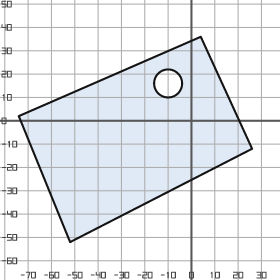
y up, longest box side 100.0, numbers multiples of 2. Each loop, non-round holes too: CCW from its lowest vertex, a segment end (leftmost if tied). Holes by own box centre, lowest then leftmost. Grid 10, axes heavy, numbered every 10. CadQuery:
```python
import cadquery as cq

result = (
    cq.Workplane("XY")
    .moveTo(-52.0, -52.0)
    .lineTo(26.0, -12.0)
    .lineTo(4.0, 36.0)
    .lineTo(-74.0, 2.0)
    .close()
    .moveTo(-10.0, 16.0)
    .circle(6.0)
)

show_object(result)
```